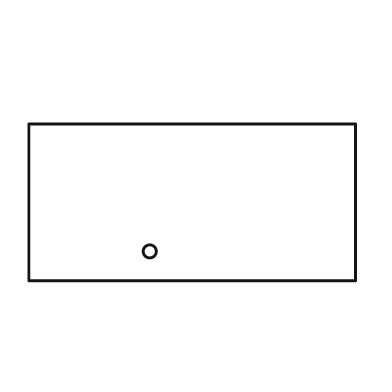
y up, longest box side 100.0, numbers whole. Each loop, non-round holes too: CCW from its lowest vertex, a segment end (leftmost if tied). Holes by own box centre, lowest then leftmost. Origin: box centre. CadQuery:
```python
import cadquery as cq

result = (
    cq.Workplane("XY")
    .moveTo(-50.0, -24.0)
    .lineTo(50.0, -24.0)
    .lineTo(50.0, 24.0)
    .lineTo(-50.0, 24.0)
    .close()
    .moveTo(-13.0, -15.0)
    .circle(2.0)
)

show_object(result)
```